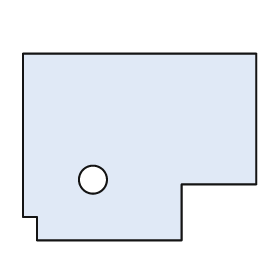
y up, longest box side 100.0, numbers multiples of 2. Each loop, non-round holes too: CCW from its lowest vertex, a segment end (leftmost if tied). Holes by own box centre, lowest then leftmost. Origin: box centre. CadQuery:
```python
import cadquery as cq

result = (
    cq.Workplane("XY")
    .moveTo(-44.0, -40.0)
    .lineTo(18.0, -40.0)
    .lineTo(18.0, -16.0)
    .lineTo(50.0, -16.0)
    .lineTo(50.0, 40.0)
    .lineTo(-50.0, 40.0)
    .lineTo(-50.0, -30.0)
    .lineTo(-44.0, -30.0)
    .close()
    .moveTo(-20.0, -14.0)
    .circle(6.0)
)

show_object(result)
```